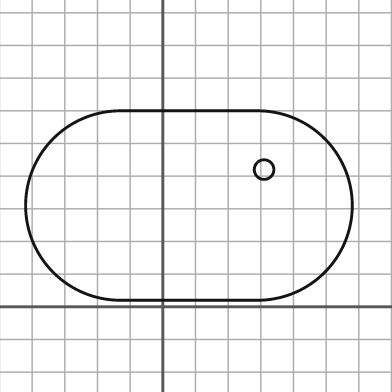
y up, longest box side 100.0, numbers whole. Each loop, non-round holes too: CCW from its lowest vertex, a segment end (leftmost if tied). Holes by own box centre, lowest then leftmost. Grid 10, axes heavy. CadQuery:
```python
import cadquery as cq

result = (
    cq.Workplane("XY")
    .moveTo(-13.0, 2.0)
    .lineTo(29.0, 2.0)
    .threePointArc((58.0, 31.0), (29.0, 60.0))
    .lineTo(-13.0, 60.0)
    .threePointArc((-42.0, 31.0), (-13.0, 2.0))
    .close()
    .moveTo(31.0, 42.0)
    .circle(3.0)
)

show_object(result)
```